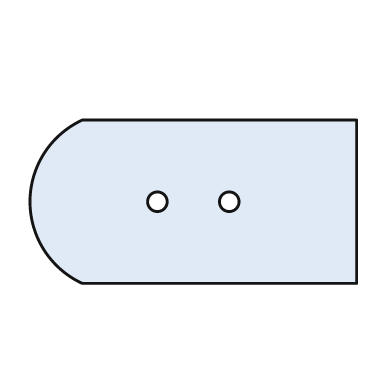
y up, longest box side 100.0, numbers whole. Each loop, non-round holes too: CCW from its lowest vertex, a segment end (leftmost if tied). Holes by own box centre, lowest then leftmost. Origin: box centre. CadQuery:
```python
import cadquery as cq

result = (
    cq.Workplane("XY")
    .moveTo(-34.0, -25.0)
    .lineTo(50.0, -25.0)
    .lineTo(50.0, 25.0)
    .lineTo(-34.0, 25.0)
    .threePointArc((-50.0, 0.0), (-34.0, -25.0))
    .close()
    .moveTo(-11.0, 0.0)
    .circle(3.0)
    .moveTo(11.0, 0.0)
    .circle(3.0)
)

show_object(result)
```